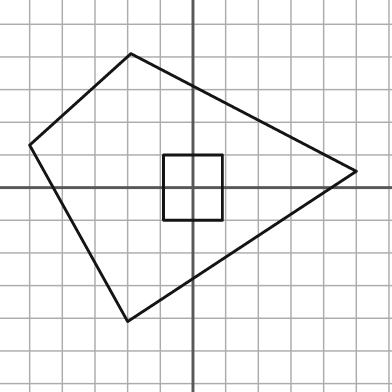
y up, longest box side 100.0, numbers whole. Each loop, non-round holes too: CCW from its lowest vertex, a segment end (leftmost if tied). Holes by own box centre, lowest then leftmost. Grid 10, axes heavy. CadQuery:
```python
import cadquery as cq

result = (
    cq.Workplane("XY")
    .moveTo(-20.0, -41.0)
    .lineTo(50.0, 5.0)
    .lineTo(-19.0, 41.0)
    .lineTo(-50.0, 13.0)
    .close()
    .moveTo(-9.0, -10.0)
    .lineTo(9.0, -10.0)
    .lineTo(9.0, 10.0)
    .lineTo(-9.0, 10.0)
    .close()
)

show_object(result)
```